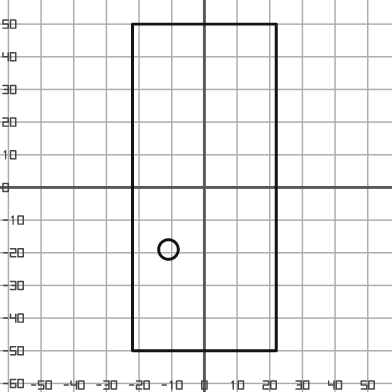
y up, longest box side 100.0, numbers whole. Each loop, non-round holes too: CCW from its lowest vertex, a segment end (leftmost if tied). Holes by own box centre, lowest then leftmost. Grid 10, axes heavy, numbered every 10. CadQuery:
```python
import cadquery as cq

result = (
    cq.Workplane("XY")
    .moveTo(-22.0, -50.0)
    .lineTo(22.0, -50.0)
    .lineTo(22.0, 50.0)
    .lineTo(-22.0, 50.0)
    .close()
    .moveTo(-11.0, -19.0)
    .circle(3.0)
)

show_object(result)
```